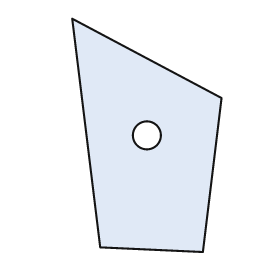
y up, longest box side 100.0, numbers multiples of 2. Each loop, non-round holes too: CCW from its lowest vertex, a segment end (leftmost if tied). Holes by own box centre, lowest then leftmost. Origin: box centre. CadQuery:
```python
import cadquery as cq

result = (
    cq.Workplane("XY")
    .moveTo(24.0, -50.0)
    .lineTo(32.0, 16.0)
    .lineTo(-32.0, 50.0)
    .lineTo(-20.0, -48.0)
    .close()
    .moveTo(0.0, 0.0)
    .circle(6.0)
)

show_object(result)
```